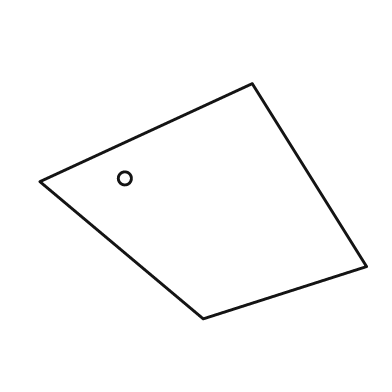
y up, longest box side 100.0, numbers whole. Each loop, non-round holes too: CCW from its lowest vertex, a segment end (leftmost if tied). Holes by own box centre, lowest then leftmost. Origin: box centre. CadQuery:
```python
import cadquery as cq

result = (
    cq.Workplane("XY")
    .moveTo(0.0, -36.0)
    .lineTo(50.0, -20.0)
    .lineTo(15.0, 36.0)
    .lineTo(-50.0, 6.0)
    .close()
    .moveTo(-24.0, 7.0)
    .circle(2.0)
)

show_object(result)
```